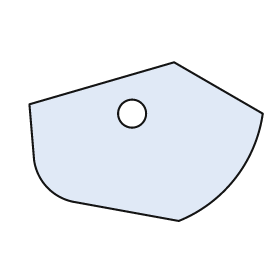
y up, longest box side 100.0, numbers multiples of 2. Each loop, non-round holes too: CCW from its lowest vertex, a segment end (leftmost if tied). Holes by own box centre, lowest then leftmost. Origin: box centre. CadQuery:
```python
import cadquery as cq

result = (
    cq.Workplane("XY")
    .moveTo(14.0, -34.0)
    .threePointArc((38.0, -16.0), (50.0, 12.0))
    .lineTo(12.0, 34.0)
    .lineTo(-50.0, 16.0)
    .lineTo(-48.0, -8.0)
    .threePointArc((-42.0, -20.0), (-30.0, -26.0))
    .close()
    .moveTo(-6.0, 12.0)
    .circle(6.0)
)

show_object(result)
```